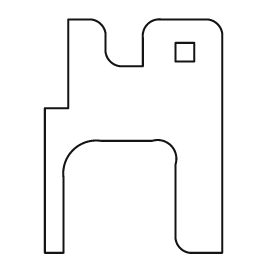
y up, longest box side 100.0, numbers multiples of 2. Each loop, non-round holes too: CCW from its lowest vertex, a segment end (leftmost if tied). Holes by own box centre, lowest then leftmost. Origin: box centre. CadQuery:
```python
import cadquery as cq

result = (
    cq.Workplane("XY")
    .moveTo(-38.0, -50.0)
    .lineTo(-30.0, -50.0)
    .lineTo(-30.0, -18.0)
    .threePointArc((-26.0, -6.0), (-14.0, -2.0))
    .lineTo(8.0, -2.0)
    .threePointArc((16.0, -4.0), (18.0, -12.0))
    .lineTo(18.0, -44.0)
    .threePointArc((20.0, -48.0), (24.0, -50.0))
    .lineTo(38.0, -50.0)
    .lineTo(38.0, 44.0)
    .threePointArc((36.0, 48.0), (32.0, 50.0))
    .lineTo(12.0, 50.0)
    .threePointArc((6.0, 48.0), (4.0, 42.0))
    .lineTo(4.0, 30.0)
    .lineTo(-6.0, 30.0)
    .threePointArc((-10.0, 32.0), (-12.0, 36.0))
    .lineTo(-12.0, 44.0)
    .threePointArc((-14.0, 48.0), (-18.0, 50.0))
    .lineTo(-28.0, 50.0)
    .lineTo(-28.0, 12.0)
    .lineTo(-38.0, 12.0)
    .close()
    .moveTo(18.0, 32.0)
    .lineTo(26.0, 32.0)
    .lineTo(26.0, 40.0)
    .lineTo(18.0, 40.0)
    .close()
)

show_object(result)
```